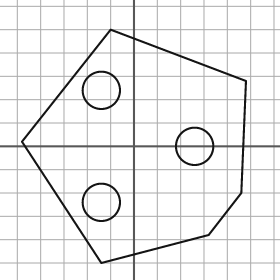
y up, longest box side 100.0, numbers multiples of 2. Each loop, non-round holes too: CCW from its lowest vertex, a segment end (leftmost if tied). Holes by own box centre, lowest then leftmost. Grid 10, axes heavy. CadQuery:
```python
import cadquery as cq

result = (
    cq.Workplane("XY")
    .moveTo(-14.0, -50.0)
    .lineTo(32.0, -38.0)
    .lineTo(46.0, -20.0)
    .lineTo(48.0, 28.0)
    .lineTo(-10.0, 50.0)
    .lineTo(-48.0, 2.0)
    .close()
    .moveTo(-14.0, -24.0)
    .circle(8.0)
    .moveTo(26.0, 0.0)
    .circle(8.0)
    .moveTo(-14.0, 24.0)
    .circle(8.0)
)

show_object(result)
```